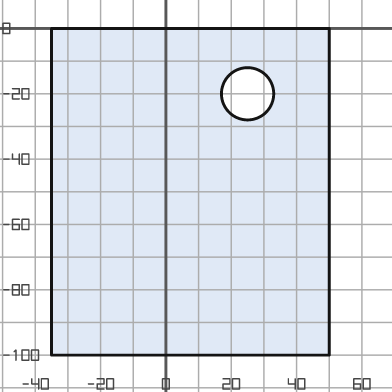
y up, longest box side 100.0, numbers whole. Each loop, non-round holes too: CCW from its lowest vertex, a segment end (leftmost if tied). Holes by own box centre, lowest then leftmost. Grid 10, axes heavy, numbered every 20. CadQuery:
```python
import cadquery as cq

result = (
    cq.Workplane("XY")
    .moveTo(-35.0, -100.0)
    .lineTo(50.0, -100.0)
    .lineTo(50.0, 0.0)
    .lineTo(-35.0, 0.0)
    .close()
    .moveTo(25.0, -20.0)
    .circle(8.0)
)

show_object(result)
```